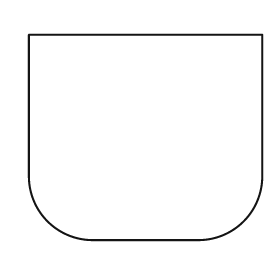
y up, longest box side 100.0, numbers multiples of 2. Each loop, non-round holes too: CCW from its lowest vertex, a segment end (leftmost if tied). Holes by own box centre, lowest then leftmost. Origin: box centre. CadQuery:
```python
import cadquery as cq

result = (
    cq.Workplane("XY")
    .moveTo(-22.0, -44.0)
    .lineTo(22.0, -44.0)
    .threePointArc((42.0, -36.0), (50.0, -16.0))
    .lineTo(50.0, 44.0)
    .lineTo(-50.0, 44.0)
    .lineTo(-50.0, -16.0)
    .threePointArc((-42.0, -36.0), (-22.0, -44.0))
    .close()
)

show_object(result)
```